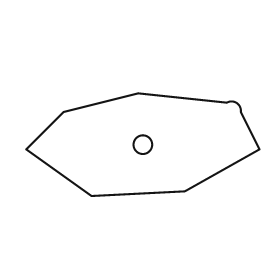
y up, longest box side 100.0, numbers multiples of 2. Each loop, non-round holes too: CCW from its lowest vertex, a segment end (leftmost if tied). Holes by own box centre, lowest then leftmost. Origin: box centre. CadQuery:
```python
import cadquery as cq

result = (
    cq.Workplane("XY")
    .moveTo(-22.0, -22.0)
    .lineTo(18.0, -20.0)
    .lineTo(50.0, -2.0)
    .lineTo(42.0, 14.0)
    .threePointArc((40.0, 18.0), (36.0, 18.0))
    .lineTo(-2.0, 22.0)
    .lineTo(-34.0, 14.0)
    .lineTo(-50.0, -2.0)
    .close()
    .moveTo(0.0, 0.0)
    .circle(4.0)
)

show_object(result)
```